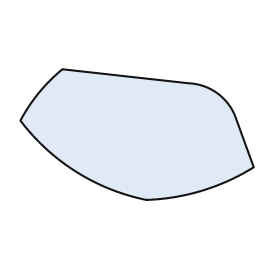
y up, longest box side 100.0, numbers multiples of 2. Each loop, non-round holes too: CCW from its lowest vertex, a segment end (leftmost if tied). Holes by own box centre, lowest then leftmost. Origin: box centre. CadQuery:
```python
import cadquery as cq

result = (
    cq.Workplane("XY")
    .moveTo(4.0, -28.0)
    .threePointArc((28.0, -24.0), (50.0, -14.0))
    .lineTo(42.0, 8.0)
    .threePointArc((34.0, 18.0), (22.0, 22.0))
    .lineTo(-32.0, 28.0)
    .threePointArc((-42.0, 18.0), (-50.0, 6.0))
    .threePointArc((-26.0, -16.0), (4.0, -28.0))
    .close()
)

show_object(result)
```